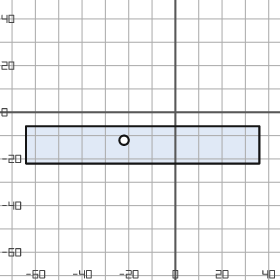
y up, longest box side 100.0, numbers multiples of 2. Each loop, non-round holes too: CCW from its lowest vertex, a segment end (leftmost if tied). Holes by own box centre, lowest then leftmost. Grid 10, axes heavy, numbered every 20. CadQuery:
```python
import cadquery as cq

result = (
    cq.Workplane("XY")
    .moveTo(-64.0, -22.0)
    .lineTo(36.0, -22.0)
    .lineTo(36.0, -6.0)
    .lineTo(-64.0, -6.0)
    .close()
    .moveTo(-22.0, -12.0)
    .circle(2.0)
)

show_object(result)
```